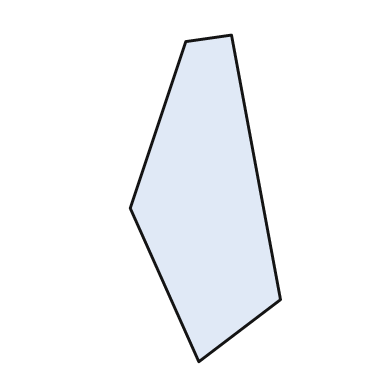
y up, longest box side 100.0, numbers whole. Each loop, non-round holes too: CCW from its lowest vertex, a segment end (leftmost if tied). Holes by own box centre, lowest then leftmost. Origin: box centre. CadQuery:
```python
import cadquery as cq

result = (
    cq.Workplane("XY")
    .moveTo(-2.0, -50.0)
    .lineTo(23.0, -31.0)
    .lineTo(8.0, 50.0)
    .lineTo(-6.0, 48.0)
    .lineTo(-23.0, -3.0)
    .close()
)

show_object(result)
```